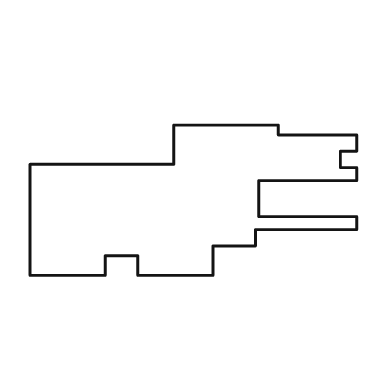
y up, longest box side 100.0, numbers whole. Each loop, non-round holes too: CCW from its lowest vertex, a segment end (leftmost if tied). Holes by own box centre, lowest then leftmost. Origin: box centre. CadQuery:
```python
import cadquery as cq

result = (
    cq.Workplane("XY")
    .moveTo(-50.0, -23.0)
    .lineTo(-27.0, -23.0)
    .lineTo(-27.0, -17.0)
    .lineTo(-17.0, -17.0)
    .lineTo(-17.0, -23.0)
    .lineTo(6.0, -23.0)
    .lineTo(6.0, -14.0)
    .lineTo(19.0, -14.0)
    .lineTo(19.0, -9.0)
    .lineTo(50.0, -9.0)
    .lineTo(50.0, -5.0)
    .lineTo(20.0, -5.0)
    .lineTo(20.0, 6.0)
    .lineTo(50.0, 6.0)
    .lineTo(50.0, 10.0)
    .lineTo(45.0, 10.0)
    .lineTo(45.0, 15.0)
    .lineTo(50.0, 15.0)
    .lineTo(50.0, 20.0)
    .lineTo(26.0, 20.0)
    .lineTo(26.0, 23.0)
    .lineTo(-6.0, 23.0)
    .lineTo(-6.0, 11.0)
    .lineTo(-50.0, 11.0)
    .close()
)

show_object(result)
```